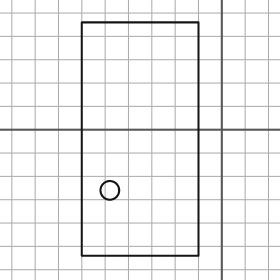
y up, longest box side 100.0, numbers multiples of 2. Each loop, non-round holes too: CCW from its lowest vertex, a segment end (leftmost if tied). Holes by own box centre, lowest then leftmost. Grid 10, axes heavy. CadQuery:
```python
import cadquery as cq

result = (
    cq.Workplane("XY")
    .moveTo(-60.0, -54.0)
    .lineTo(-10.0, -54.0)
    .lineTo(-10.0, 46.0)
    .lineTo(-60.0, 46.0)
    .close()
    .moveTo(-48.0, -26.0)
    .circle(4.0)
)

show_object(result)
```